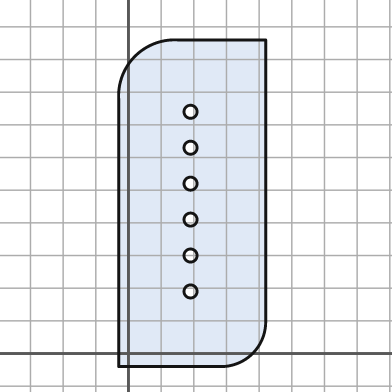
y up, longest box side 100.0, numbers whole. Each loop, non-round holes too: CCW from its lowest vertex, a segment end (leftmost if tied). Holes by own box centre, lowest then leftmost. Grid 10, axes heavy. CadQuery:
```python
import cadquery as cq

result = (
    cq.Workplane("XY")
    .moveTo(-3.0, -4.0)
    .lineTo(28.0, -4.0)
    .threePointArc((38.0, 0.0), (42.0, 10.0))
    .lineTo(42.0, 96.0)
    .lineTo(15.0, 96.0)
    .threePointArc((2.0, 91.0), (-3.0, 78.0))
    .close()
    .moveTo(19.0, 19.0)
    .circle(2.0)
    .moveTo(19.0, 30.0)
    .circle(2.0)
    .moveTo(19.0, 41.0)
    .circle(2.0)
    .moveTo(19.0, 52.0)
    .circle(2.0)
    .moveTo(19.0, 63.0)
    .circle(2.0)
    .moveTo(19.0, 74.0)
    .circle(2.0)
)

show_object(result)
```